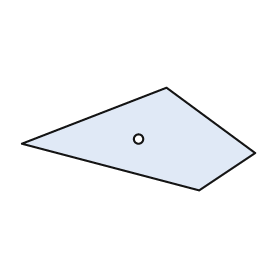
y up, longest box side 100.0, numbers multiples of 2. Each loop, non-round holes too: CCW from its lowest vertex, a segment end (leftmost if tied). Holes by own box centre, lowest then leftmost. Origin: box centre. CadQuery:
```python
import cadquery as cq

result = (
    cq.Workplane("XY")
    .moveTo(26.0, -22.0)
    .lineTo(50.0, -6.0)
    .lineTo(12.0, 22.0)
    .lineTo(-50.0, -2.0)
    .close()
    .moveTo(0.0, 0.0)
    .circle(2.0)
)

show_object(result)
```